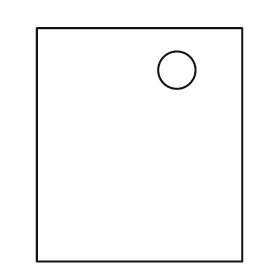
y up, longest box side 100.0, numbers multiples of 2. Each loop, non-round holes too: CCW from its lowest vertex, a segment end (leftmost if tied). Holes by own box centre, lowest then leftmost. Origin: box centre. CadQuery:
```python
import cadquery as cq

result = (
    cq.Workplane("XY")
    .moveTo(-44.0, -50.0)
    .lineTo(44.0, -50.0)
    .lineTo(44.0, 50.0)
    .lineTo(-44.0, 50.0)
    .close()
    .moveTo(16.0, 32.0)
    .circle(8.0)
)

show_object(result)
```